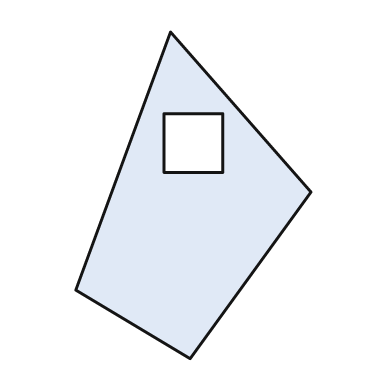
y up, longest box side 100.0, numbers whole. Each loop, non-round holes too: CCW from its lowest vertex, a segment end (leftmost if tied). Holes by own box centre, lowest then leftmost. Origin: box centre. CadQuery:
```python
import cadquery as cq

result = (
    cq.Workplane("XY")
    .moveTo(-1.0, -50.0)
    .lineTo(36.0, 1.0)
    .lineTo(-7.0, 50.0)
    .lineTo(-36.0, -29.0)
    .close()
    .moveTo(-9.0, 7.0)
    .lineTo(9.0, 7.0)
    .lineTo(9.0, 25.0)
    .lineTo(-9.0, 25.0)
    .close()
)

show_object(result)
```